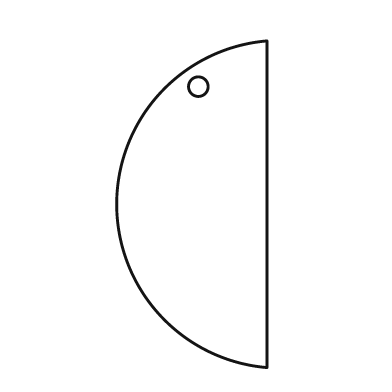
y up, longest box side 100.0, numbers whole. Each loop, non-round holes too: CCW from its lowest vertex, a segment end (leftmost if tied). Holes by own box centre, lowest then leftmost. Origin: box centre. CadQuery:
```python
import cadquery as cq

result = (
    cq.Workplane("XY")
    .moveTo(23.0, -50.0)
    .lineTo(23.0, 50.0)
    .threePointArc((-23.0, 0.0), (23.0, -50.0))
    .close()
    .moveTo(2.0, 36.0)
    .circle(3.0)
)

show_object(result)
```